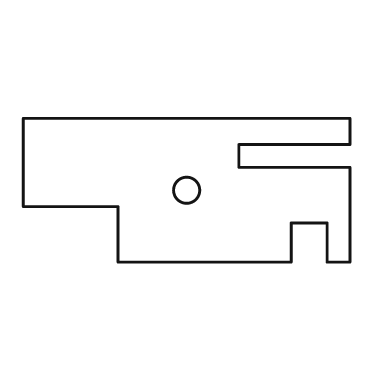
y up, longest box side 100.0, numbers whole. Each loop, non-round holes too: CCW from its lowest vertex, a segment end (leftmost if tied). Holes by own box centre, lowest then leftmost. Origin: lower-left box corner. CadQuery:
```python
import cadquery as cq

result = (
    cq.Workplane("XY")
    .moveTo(29.0, 0.0)
    .lineTo(82.0, 0.0)
    .lineTo(82.0, 12.0)
    .lineTo(93.0, 12.0)
    .lineTo(93.0, 0.0)
    .lineTo(100.0, 0.0)
    .lineTo(100.0, 29.0)
    .lineTo(66.0, 29.0)
    .lineTo(66.0, 36.0)
    .lineTo(100.0, 36.0)
    .lineTo(100.0, 44.0)
    .lineTo(0.0, 44.0)
    .lineTo(0.0, 17.0)
    .lineTo(29.0, 17.0)
    .close()
    .moveTo(50.0, 22.0)
    .circle(4.0)
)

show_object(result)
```